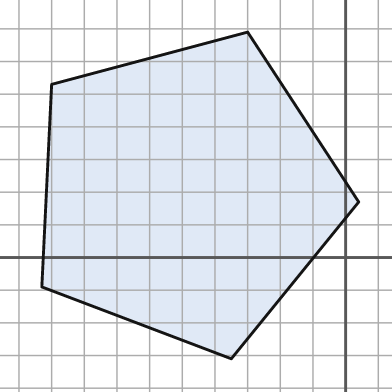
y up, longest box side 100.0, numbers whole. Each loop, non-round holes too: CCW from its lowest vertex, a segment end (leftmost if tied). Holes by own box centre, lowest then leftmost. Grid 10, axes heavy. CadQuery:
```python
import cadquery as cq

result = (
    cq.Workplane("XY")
    .moveTo(-35.0, -31.0)
    .lineTo(4.0, 17.0)
    .lineTo(-30.0, 69.0)
    .lineTo(-90.0, 53.0)
    .lineTo(-93.0, -9.0)
    .close()
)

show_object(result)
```